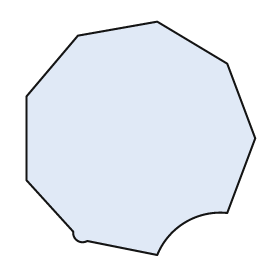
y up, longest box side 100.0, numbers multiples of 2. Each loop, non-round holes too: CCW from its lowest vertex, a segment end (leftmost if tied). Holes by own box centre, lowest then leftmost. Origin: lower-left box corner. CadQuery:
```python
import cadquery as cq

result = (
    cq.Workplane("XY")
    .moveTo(56.0, 0.0)
    .threePointArc((68.0, 14.0), (86.0, 18.0))
    .lineTo(98.0, 50.0)
    .lineTo(86.0, 82.0)
    .lineTo(56.0, 100.0)
    .lineTo(22.0, 94.0)
    .lineTo(0.0, 68.0)
    .lineTo(0.0, 32.0)
    .lineTo(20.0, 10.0)
    .threePointArc((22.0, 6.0), (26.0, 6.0))
    .close()
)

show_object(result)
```